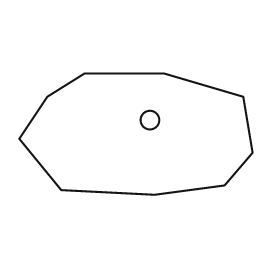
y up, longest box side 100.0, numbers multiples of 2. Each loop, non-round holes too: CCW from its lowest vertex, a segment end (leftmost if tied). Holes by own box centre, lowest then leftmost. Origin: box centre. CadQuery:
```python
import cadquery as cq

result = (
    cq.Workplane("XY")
    .moveTo(8.0, -26.0)
    .lineTo(38.0, -22.0)
    .lineTo(50.0, -8.0)
    .lineTo(46.0, 16.0)
    .lineTo(12.0, 26.0)
    .lineTo(-22.0, 26.0)
    .lineTo(-38.0, 16.0)
    .lineTo(-50.0, -2.0)
    .lineTo(-32.0, -24.0)
    .close()
    .moveTo(6.0, 6.0)
    .circle(4.0)
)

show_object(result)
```